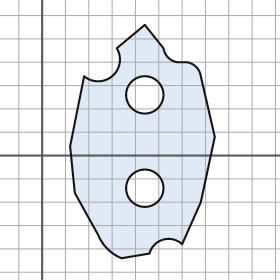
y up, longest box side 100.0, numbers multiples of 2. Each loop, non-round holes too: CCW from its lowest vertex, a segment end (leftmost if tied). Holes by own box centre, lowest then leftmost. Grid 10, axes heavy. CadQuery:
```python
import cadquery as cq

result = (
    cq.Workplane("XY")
    .moveTo(34.0, -44.0)
    .lineTo(46.0, -42.0)
    .threePointArc((52.0, -36.0), (60.0, -38.0))
    .lineTo(68.0, -20.0)
    .lineTo(74.0, 8.0)
    .lineTo(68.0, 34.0)
    .threePointArc((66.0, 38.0), (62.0, 40.0))
    .lineTo(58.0, 40.0)
    .threePointArc((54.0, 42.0), (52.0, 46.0))
    .lineTo(44.0, 56.0)
    .lineTo(32.0, 46.0)
    .threePointArc((30.0, 34.0), (18.0, 34.0))
    .lineTo(12.0, 4.0)
    .lineTo(14.0, -16.0)
    .lineTo(24.0, -34.0)
    .threePointArc((28.0, -40.0), (34.0, -44.0))
    .close()
    .moveTo(44.0, -14.0)
    .circle(8.0)
    .moveTo(44.0, 26.0)
    .circle(8.0)
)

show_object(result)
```